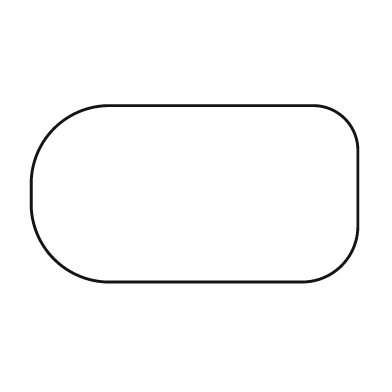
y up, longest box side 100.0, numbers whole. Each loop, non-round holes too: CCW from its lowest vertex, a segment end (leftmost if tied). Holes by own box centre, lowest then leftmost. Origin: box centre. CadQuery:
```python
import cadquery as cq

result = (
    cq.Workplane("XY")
    .moveTo(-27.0, -27.0)
    .lineTo(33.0, -27.0)
    .threePointArc((45.0, -22.0), (50.0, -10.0))
    .lineTo(50.0, 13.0)
    .threePointArc((46.0, 23.0), (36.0, 27.0))
    .lineTo(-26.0, 27.0)
    .threePointArc((-43.0, 20.0), (-50.0, 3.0))
    .lineTo(-50.0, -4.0)
    .threePointArc((-43.0, -20.0), (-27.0, -27.0))
    .close()
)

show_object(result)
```